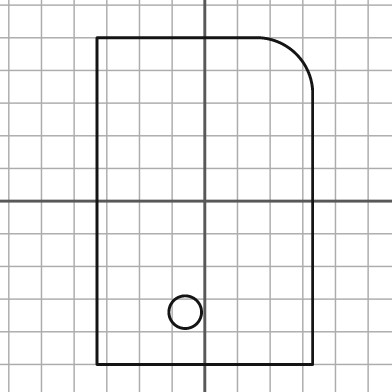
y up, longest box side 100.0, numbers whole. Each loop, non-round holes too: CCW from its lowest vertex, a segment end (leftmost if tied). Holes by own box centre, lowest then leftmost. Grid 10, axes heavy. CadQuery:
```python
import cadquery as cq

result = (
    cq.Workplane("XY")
    .moveTo(-33.0, -50.0)
    .lineTo(33.0, -50.0)
    .lineTo(33.0, 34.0)
    .threePointArc((28.0, 45.0), (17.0, 50.0))
    .lineTo(-33.0, 50.0)
    .close()
    .moveTo(-6.0, -34.0)
    .circle(5.0)
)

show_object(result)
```